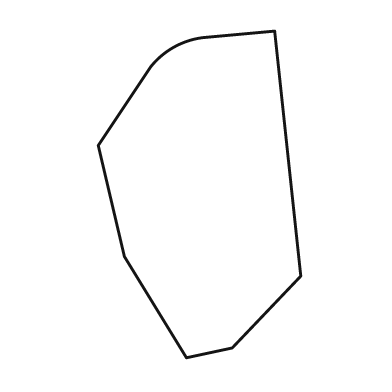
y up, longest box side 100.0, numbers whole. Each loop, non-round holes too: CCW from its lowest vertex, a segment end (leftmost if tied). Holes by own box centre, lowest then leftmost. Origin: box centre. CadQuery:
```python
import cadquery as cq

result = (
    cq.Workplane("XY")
    .moveTo(-4.0, -50.0)
    .lineTo(10.0, -47.0)
    .lineTo(31.0, -25.0)
    .lineTo(23.0, 50.0)
    .lineTo(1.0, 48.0)
    .threePointArc((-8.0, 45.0), (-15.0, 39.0))
    .lineTo(-31.0, 15.0)
    .lineTo(-23.0, -19.0)
    .close()
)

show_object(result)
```